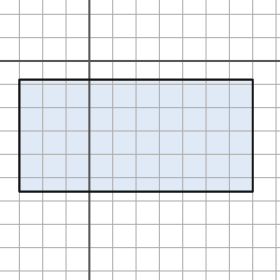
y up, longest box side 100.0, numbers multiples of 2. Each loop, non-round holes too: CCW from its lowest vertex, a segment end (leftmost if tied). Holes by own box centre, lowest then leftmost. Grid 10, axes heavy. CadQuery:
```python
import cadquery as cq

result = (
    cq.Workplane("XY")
    .moveTo(-30.0, -56.0)
    .lineTo(70.0, -56.0)
    .lineTo(70.0, -8.0)
    .lineTo(-30.0, -8.0)
    .close()
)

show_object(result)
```